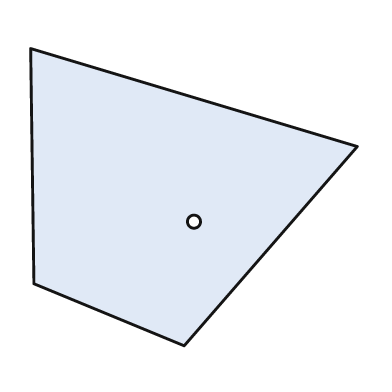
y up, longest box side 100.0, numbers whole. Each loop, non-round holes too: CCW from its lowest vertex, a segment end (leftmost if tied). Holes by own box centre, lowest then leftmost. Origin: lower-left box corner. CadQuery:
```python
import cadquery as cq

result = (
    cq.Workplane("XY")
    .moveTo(47.0, 0.0)
    .lineTo(100.0, 61.0)
    .lineTo(0.0, 91.0)
    .lineTo(1.0, 19.0)
    .close()
    .moveTo(50.0, 38.0)
    .circle(2.0)
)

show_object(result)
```